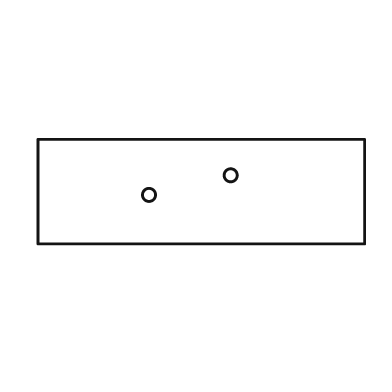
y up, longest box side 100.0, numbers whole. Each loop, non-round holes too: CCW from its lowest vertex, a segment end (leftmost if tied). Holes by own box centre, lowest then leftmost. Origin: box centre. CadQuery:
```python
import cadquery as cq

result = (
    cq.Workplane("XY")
    .moveTo(-50.0, -16.0)
    .lineTo(50.0, -16.0)
    .lineTo(50.0, 16.0)
    .lineTo(-50.0, 16.0)
    .close()
    .moveTo(-16.0, -1.0)
    .circle(2.0)
    .moveTo(9.0, 5.0)
    .circle(2.0)
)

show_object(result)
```